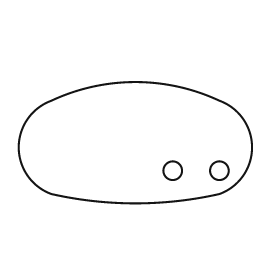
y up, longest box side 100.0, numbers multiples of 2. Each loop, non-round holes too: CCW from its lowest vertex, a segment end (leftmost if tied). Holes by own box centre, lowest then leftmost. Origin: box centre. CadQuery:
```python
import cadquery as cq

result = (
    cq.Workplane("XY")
    .moveTo(-36.0, -22.0)
    .threePointArc((0.0, -26.0), (36.0, -22.0))
    .threePointArc((50.0, -2.0), (36.0, 18.0))
    .threePointArc((0.0, 26.0), (-36.0, 18.0))
    .threePointArc((-50.0, -2.0), (-36.0, -22.0))
    .close()
    .moveTo(16.0, -12.0)
    .circle(4.0)
    .moveTo(36.0, -12.0)
    .circle(4.0)
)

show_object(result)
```